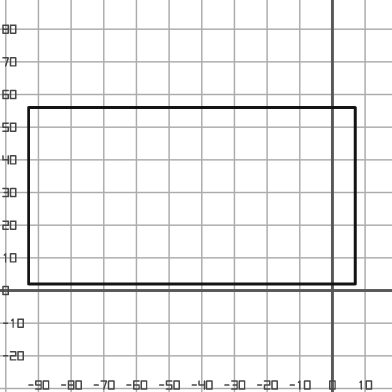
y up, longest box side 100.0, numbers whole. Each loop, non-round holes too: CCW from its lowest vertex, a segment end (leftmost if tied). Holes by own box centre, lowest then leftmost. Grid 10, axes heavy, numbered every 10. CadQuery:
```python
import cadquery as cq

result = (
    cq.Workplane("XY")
    .moveTo(-93.0, 2.0)
    .lineTo(7.0, 2.0)
    .lineTo(7.0, 56.0)
    .lineTo(-93.0, 56.0)
    .close()
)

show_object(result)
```